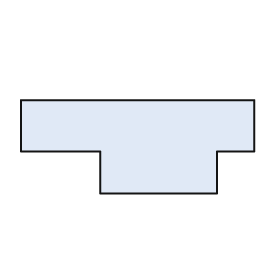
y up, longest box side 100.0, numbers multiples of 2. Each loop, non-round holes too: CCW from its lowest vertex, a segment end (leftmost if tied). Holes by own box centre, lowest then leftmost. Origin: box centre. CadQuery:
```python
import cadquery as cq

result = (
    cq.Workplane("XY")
    .moveTo(-16.0, -20.0)
    .lineTo(34.0, -20.0)
    .lineTo(34.0, -2.0)
    .lineTo(50.0, -2.0)
    .lineTo(50.0, 20.0)
    .lineTo(-50.0, 20.0)
    .lineTo(-50.0, -2.0)
    .lineTo(-16.0, -2.0)
    .close()
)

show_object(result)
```